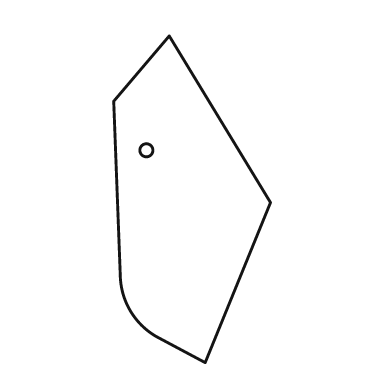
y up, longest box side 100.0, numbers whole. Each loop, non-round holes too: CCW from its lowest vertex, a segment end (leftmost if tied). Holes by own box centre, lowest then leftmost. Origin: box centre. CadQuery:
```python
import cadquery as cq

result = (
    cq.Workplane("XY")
    .moveTo(4.0, -50.0)
    .lineTo(24.0, -1.0)
    .lineTo(-7.0, 50.0)
    .lineTo(-24.0, 30.0)
    .lineTo(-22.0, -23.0)
    .threePointArc((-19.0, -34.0), (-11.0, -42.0))
    .close()
    .moveTo(-14.0, 15.0)
    .circle(2.0)
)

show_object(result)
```